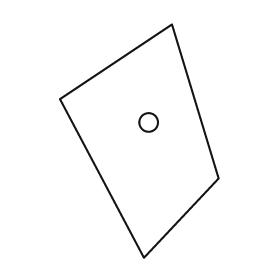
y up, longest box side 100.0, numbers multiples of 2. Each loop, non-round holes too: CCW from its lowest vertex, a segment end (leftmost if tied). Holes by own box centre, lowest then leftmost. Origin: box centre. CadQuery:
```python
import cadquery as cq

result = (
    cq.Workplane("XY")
    .moveTo(2.0, -50.0)
    .lineTo(34.0, -16.0)
    .lineTo(14.0, 50.0)
    .lineTo(-34.0, 18.0)
    .close()
    .moveTo(4.0, 8.0)
    .circle(4.0)
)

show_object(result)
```